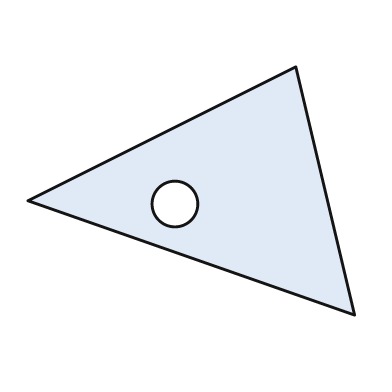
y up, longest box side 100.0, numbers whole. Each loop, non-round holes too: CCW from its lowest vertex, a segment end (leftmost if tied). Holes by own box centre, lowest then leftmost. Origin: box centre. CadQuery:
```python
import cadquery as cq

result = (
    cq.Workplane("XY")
    .moveTo(50.0, -38.0)
    .lineTo(32.0, 38.0)
    .lineTo(-50.0, -3.0)
    .close()
    .moveTo(-5.0, -4.0)
    .circle(7.0)
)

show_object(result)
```